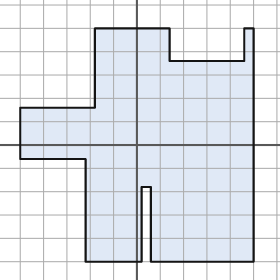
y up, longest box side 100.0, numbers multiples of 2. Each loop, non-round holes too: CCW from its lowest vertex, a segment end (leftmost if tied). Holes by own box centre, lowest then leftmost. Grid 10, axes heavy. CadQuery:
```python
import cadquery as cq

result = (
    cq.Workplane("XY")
    .moveTo(-22.0, -50.0)
    .lineTo(2.0, -50.0)
    .lineTo(2.0, -18.0)
    .lineTo(6.0, -18.0)
    .lineTo(6.0, -50.0)
    .lineTo(50.0, -50.0)
    .lineTo(50.0, 50.0)
    .lineTo(46.0, 50.0)
    .lineTo(46.0, 36.0)
    .lineTo(14.0, 36.0)
    .lineTo(14.0, 50.0)
    .lineTo(-18.0, 50.0)
    .lineTo(-18.0, 16.0)
    .lineTo(-50.0, 16.0)
    .lineTo(-50.0, -6.0)
    .lineTo(-22.0, -6.0)
    .close()
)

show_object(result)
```